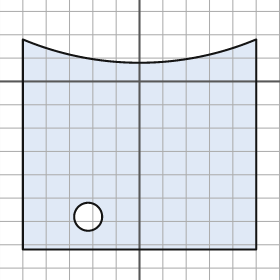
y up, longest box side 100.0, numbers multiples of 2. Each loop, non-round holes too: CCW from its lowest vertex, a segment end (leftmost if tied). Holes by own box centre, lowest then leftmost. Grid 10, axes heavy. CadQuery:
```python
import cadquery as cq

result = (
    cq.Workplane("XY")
    .moveTo(-50.0, -72.0)
    .lineTo(50.0, -72.0)
    .lineTo(50.0, 18.0)
    .threePointArc((0.0, 8.0), (-50.0, 18.0))
    .close()
    .moveTo(-22.0, -58.0)
    .circle(6.0)
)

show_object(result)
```